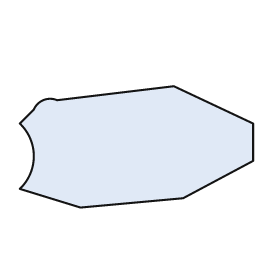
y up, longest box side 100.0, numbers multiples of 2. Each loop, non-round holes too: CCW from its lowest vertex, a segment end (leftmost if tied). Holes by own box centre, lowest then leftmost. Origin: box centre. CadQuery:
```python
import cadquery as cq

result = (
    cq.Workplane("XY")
    .moveTo(-24.0, -26.0)
    .lineTo(20.0, -22.0)
    .lineTo(50.0, -6.0)
    .lineTo(50.0, 10.0)
    .lineTo(16.0, 26.0)
    .lineTo(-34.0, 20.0)
    .threePointArc((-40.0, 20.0), (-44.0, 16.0))
    .lineTo(-50.0, 10.0)
    .threePointArc((-44.0, -4.0), (-50.0, -18.0))
    .close()
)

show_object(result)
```